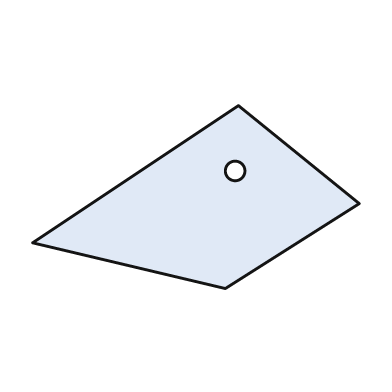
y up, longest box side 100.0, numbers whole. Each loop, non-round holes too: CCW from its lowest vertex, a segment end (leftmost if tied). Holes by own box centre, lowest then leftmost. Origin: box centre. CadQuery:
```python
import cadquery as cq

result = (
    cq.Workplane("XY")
    .moveTo(9.0, -28.0)
    .lineTo(50.0, -2.0)
    .lineTo(13.0, 28.0)
    .lineTo(-50.0, -14.0)
    .close()
    .moveTo(12.0, 8.0)
    .circle(3.0)
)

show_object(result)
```